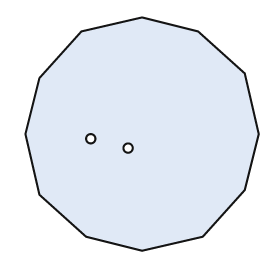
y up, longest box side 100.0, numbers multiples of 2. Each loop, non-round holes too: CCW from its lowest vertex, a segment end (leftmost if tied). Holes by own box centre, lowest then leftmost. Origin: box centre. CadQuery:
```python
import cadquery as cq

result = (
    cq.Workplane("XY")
    .moveTo(0.0, -50.0)
    .lineTo(26.0, -44.0)
    .lineTo(44.0, -24.0)
    .lineTo(50.0, 0.0)
    .lineTo(44.0, 26.0)
    .lineTo(24.0, 44.0)
    .lineTo(0.0, 50.0)
    .lineTo(-26.0, 44.0)
    .lineTo(-44.0, 24.0)
    .lineTo(-50.0, 0.0)
    .lineTo(-44.0, -26.0)
    .lineTo(-24.0, -44.0)
    .close()
    .moveTo(-6.0, -6.0)
    .circle(2.0)
    .moveTo(-22.0, -2.0)
    .circle(2.0)
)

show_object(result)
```